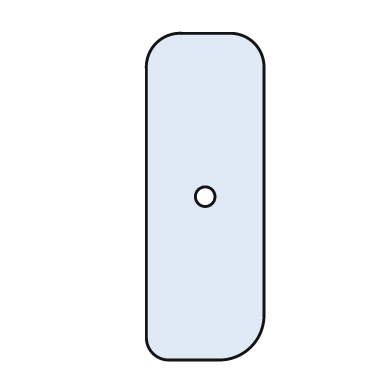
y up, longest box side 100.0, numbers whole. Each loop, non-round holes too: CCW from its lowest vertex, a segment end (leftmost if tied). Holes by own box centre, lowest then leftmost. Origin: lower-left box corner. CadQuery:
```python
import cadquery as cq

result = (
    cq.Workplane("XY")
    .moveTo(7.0, 0.0)
    .lineTo(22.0, 0.0)
    .threePointArc((32.0, 4.0), (36.0, 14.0))
    .lineTo(36.0, 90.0)
    .threePointArc((33.0, 97.0), (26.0, 100.0))
    .lineTo(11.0, 100.0)
    .threePointArc((3.0, 97.0), (0.0, 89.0))
    .lineTo(0.0, 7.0)
    .threePointArc((2.0, 2.0), (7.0, 0.0))
    .close()
    .moveTo(18.0, 50.0)
    .circle(3.0)
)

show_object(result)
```